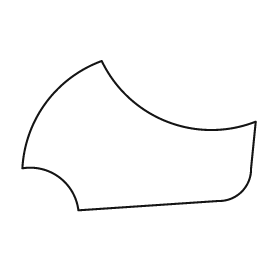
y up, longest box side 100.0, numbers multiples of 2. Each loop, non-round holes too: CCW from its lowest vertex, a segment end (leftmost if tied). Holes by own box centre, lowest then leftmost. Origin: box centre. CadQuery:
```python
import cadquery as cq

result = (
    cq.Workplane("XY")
    .moveTo(-26.0, -32.0)
    .lineTo(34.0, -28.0)
    .threePointArc((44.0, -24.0), (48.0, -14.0))
    .lineTo(50.0, 6.0)
    .threePointArc((12.0, 6.0), (-16.0, 32.0))
    .threePointArc((-40.0, 14.0), (-50.0, -14.0))
    .threePointArc((-34.0, -18.0), (-26.0, -32.0))
    .close()
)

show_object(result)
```